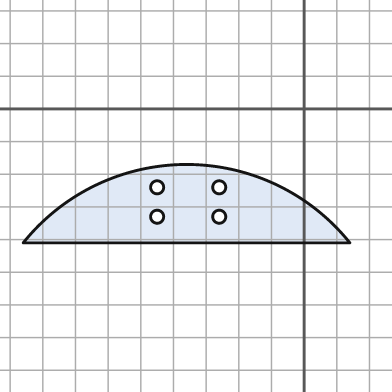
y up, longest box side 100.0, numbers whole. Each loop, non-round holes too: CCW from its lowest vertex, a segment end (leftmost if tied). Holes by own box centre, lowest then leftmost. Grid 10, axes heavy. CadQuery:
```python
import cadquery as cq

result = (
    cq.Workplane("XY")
    .moveTo(-86.0, -41.0)
    .lineTo(14.0, -41.0)
    .threePointArc((-36.0, -17.0), (-86.0, -41.0))
    .close()
    .moveTo(-45.0, -33.0)
    .circle(2.0)
    .moveTo(-26.0, -33.0)
    .circle(2.0)
    .moveTo(-45.0, -24.0)
    .circle(2.0)
    .moveTo(-26.0, -24.0)
    .circle(2.0)
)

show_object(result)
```